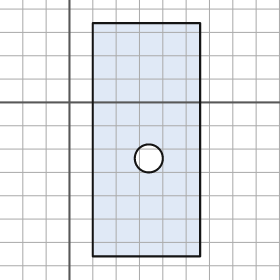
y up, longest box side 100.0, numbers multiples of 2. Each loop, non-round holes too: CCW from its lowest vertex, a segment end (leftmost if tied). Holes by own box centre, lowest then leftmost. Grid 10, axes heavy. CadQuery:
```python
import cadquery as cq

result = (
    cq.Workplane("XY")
    .moveTo(10.0, -66.0)
    .lineTo(56.0, -66.0)
    .lineTo(56.0, 34.0)
    .lineTo(10.0, 34.0)
    .close()
    .moveTo(34.0, -24.0)
    .circle(6.0)
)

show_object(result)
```